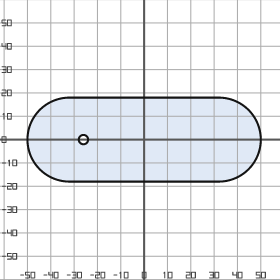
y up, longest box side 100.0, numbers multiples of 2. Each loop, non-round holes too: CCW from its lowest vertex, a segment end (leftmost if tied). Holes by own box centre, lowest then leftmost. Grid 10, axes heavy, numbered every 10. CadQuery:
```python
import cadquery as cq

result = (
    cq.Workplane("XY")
    .moveTo(-32.0, -18.0)
    .lineTo(32.0, -18.0)
    .threePointArc((50.0, 0.0), (32.0, 18.0))
    .lineTo(-32.0, 18.0)
    .threePointArc((-50.0, 0.0), (-32.0, -18.0))
    .close()
    .moveTo(-26.0, 0.0)
    .circle(2.0)
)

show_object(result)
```